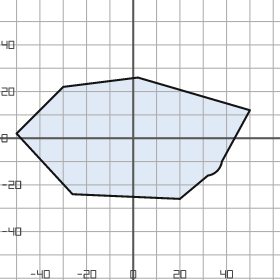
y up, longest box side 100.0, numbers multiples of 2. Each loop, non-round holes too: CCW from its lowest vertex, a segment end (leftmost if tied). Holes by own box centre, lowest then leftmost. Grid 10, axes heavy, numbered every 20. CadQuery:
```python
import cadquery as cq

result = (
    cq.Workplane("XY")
    .moveTo(20.0, -26.0)
    .lineTo(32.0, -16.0)
    .threePointArc((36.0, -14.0), (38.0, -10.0))
    .lineTo(50.0, 12.0)
    .lineTo(2.0, 26.0)
    .lineTo(-30.0, 22.0)
    .lineTo(-50.0, 2.0)
    .lineTo(-26.0, -24.0)
    .close()
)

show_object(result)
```